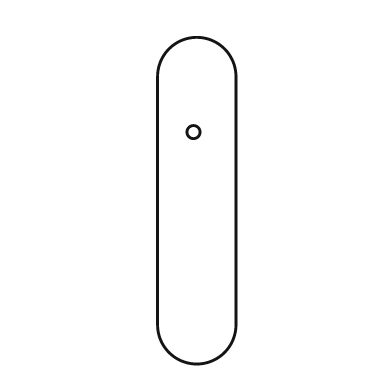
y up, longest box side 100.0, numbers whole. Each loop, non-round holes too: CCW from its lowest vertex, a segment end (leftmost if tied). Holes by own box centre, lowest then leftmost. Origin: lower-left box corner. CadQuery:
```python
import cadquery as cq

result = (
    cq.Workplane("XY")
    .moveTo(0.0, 12.0)
    .threePointArc((12.0, 0.0), (24.0, 12.0))
    .lineTo(24.0, 88.0)
    .threePointArc((12.0, 100.0), (0.0, 88.0))
    .close()
    .moveTo(11.0, 71.0)
    .circle(2.0)
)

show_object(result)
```